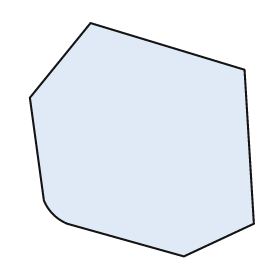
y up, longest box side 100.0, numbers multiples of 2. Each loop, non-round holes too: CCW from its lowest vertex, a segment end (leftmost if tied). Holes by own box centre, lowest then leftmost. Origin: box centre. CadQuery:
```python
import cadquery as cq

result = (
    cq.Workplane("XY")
    .moveTo(18.0, -50.0)
    .lineTo(48.0, -36.0)
    .lineTo(44.0, 30.0)
    .lineTo(-22.0, 50.0)
    .lineTo(-48.0, 18.0)
    .lineTo(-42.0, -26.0)
    .threePointArc((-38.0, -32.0), (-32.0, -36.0))
    .close()
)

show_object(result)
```